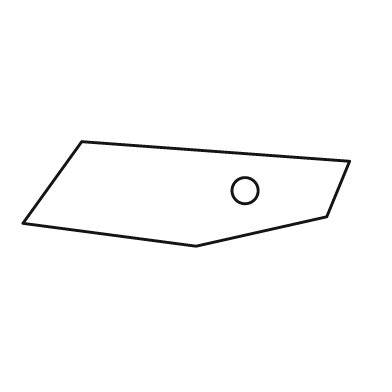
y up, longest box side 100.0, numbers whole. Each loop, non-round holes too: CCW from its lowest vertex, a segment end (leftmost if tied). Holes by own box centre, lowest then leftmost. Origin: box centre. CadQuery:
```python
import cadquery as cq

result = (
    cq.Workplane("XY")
    .moveTo(3.0, -16.0)
    .lineTo(43.0, -7.0)
    .lineTo(50.0, 10.0)
    .lineTo(-32.0, 16.0)
    .lineTo(-50.0, -9.0)
    .close()
    .moveTo(18.0, 1.0)
    .circle(4.0)
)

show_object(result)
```